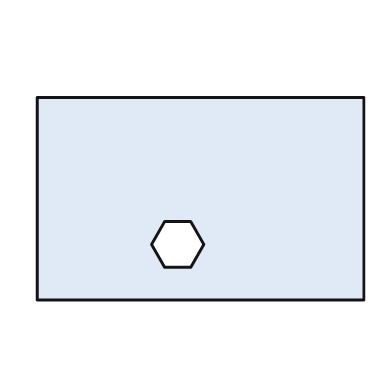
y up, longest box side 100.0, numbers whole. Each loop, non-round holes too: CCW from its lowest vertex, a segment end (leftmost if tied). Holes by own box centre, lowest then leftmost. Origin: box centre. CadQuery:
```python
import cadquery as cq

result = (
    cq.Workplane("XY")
    .moveTo(-50.0, -31.0)
    .lineTo(50.0, -31.0)
    .lineTo(50.0, 31.0)
    .lineTo(-50.0, 31.0)
    .close()
    .moveTo(-11.0, -21.0)
    .lineTo(-3.0, -21.0)
    .lineTo(1.0, -14.0)
    .lineTo(-3.0, -7.0)
    .lineTo(-11.0, -7.0)
    .lineTo(-15.0, -14.0)
    .close()
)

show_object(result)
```